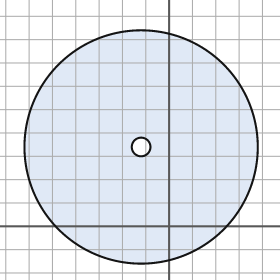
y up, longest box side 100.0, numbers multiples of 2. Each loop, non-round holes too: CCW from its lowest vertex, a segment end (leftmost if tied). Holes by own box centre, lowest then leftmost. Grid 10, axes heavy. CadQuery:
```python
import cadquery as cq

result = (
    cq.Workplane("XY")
    .moveTo(-12.0, 34.0)
    .circle(50.0)
    .moveTo(-12.0, 34.0)
    .circle(4.0)
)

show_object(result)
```